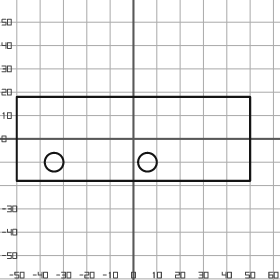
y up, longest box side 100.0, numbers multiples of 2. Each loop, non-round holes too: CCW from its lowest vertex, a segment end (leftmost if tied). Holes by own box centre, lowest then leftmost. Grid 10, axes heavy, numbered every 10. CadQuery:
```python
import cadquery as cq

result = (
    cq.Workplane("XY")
    .moveTo(-50.0, -18.0)
    .lineTo(50.0, -18.0)
    .lineTo(50.0, 18.0)
    .lineTo(-50.0, 18.0)
    .close()
    .moveTo(-34.0, -10.0)
    .circle(4.0)
    .moveTo(6.0, -10.0)
    .circle(4.0)
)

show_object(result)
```